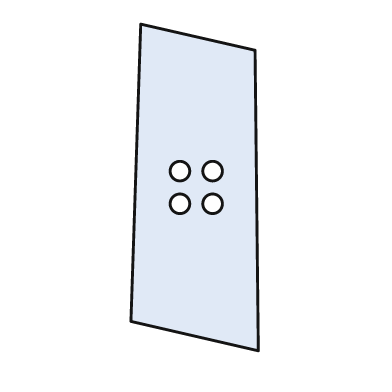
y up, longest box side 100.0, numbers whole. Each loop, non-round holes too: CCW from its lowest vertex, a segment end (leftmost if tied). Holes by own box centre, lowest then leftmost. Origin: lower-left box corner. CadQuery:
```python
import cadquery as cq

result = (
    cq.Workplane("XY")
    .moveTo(39.0, 0.0)
    .lineTo(38.0, 92.0)
    .lineTo(3.0, 100.0)
    .lineTo(0.0, 9.0)
    .close()
    .moveTo(15.0, 45.0)
    .circle(3.0)
    .moveTo(25.0, 45.0)
    .circle(3.0)
    .moveTo(15.0, 55.0)
    .circle(3.0)
    .moveTo(25.0, 55.0)
    .circle(3.0)
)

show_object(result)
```